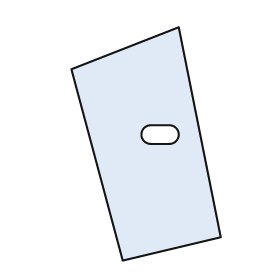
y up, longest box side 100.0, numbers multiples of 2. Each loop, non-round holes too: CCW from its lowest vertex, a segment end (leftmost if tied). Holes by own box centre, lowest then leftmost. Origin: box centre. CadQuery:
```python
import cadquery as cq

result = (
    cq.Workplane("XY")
    .moveTo(-10.0, -50.0)
    .lineTo(32.0, -40.0)
    .lineTo(14.0, 50.0)
    .lineTo(-32.0, 32.0)
    .close()
    .moveTo(2.0, 0.0)
    .lineTo(10.0, 0.0)
    .threePointArc((14.0, 4.0), (10.0, 8.0))
    .lineTo(2.0, 8.0)
    .threePointArc((-2.0, 4.0), (2.0, 0.0))
    .close()
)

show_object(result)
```